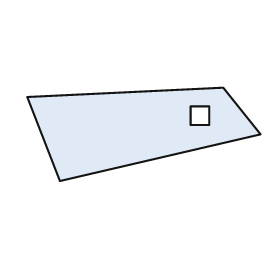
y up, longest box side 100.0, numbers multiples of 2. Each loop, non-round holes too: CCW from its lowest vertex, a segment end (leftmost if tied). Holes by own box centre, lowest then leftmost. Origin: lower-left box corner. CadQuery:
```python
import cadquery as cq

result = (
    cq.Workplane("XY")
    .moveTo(14.0, 0.0)
    .lineTo(100.0, 20.0)
    .lineTo(84.0, 40.0)
    .lineTo(0.0, 36.0)
    .close()
    .moveTo(70.0, 24.0)
    .lineTo(78.0, 24.0)
    .lineTo(78.0, 32.0)
    .lineTo(70.0, 32.0)
    .close()
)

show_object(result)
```